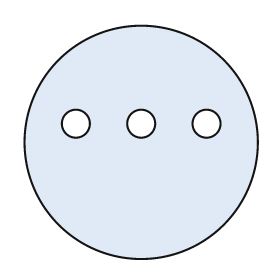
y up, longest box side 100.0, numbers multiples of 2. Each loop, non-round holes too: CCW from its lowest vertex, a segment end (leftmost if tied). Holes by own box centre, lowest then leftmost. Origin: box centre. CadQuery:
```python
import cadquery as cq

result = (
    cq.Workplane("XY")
    .moveTo(0.0, 0.0)
    .circle(50.0)
    .moveTo(-28.0, 8.0)
    .circle(6.0)
    .moveTo(0.0, 8.0)
    .circle(6.0)
    .moveTo(28.0, 8.0)
    .circle(6.0)
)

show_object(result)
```